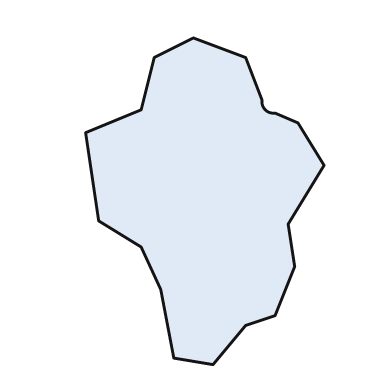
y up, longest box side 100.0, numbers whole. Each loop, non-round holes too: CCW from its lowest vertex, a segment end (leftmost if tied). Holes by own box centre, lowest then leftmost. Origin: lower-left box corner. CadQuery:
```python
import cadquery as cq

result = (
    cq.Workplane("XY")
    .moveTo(39.0, 0.0)
    .lineTo(49.0, 12.0)
    .lineTo(58.0, 15.0)
    .lineTo(64.0, 30.0)
    .lineTo(62.0, 43.0)
    .lineTo(73.0, 61.0)
    .lineTo(65.0, 74.0)
    .lineTo(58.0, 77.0)
    .threePointArc((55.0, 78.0), (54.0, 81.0))
    .lineTo(49.0, 94.0)
    .lineTo(33.0, 100.0)
    .lineTo(21.0, 94.0)
    .lineTo(17.0, 78.0)
    .lineTo(0.0, 71.0)
    .lineTo(4.0, 44.0)
    .lineTo(17.0, 36.0)
    .lineTo(23.0, 23.0)
    .lineTo(27.0, 2.0)
    .close()
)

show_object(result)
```